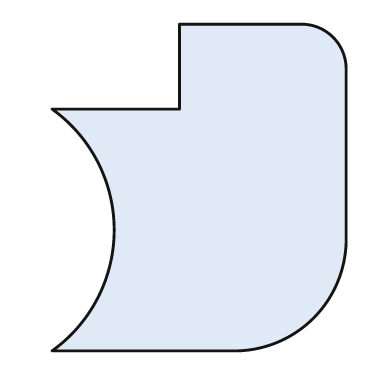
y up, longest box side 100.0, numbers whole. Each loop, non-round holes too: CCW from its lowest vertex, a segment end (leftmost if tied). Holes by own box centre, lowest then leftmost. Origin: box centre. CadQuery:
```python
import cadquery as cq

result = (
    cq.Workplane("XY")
    .moveTo(-45.0, -50.0)
    .lineTo(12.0, -50.0)
    .threePointArc((35.0, -40.0), (45.0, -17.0))
    .lineTo(45.0, 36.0)
    .threePointArc((41.0, 46.0), (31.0, 50.0))
    .lineTo(-6.0, 50.0)
    .lineTo(-6.0, 24.0)
    .lineTo(-45.0, 24.0)
    .threePointArc((-26.0, -13.0), (-45.0, -50.0))
    .close()
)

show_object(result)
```